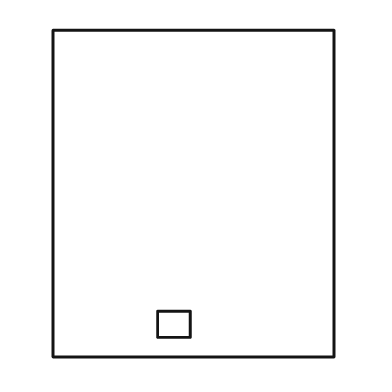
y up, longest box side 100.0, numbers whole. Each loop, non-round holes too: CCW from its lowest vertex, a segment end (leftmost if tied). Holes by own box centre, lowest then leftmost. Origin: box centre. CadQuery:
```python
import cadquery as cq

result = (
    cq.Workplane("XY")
    .moveTo(-43.0, -50.0)
    .lineTo(43.0, -50.0)
    .lineTo(43.0, 50.0)
    .lineTo(-43.0, 50.0)
    .close()
    .moveTo(-11.0, -44.0)
    .lineTo(-1.0, -44.0)
    .lineTo(-1.0, -36.0)
    .lineTo(-11.0, -36.0)
    .close()
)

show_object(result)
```